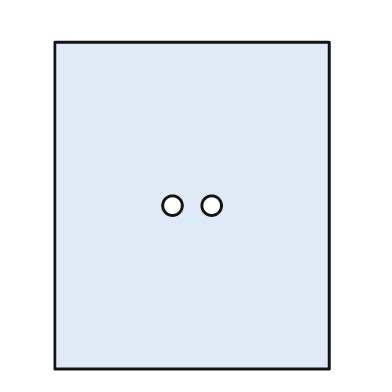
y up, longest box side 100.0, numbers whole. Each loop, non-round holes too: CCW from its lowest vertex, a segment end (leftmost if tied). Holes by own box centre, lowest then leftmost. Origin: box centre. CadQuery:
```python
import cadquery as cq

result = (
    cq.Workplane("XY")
    .moveTo(-42.0, -50.0)
    .lineTo(42.0, -50.0)
    .lineTo(42.0, 50.0)
    .lineTo(-42.0, 50.0)
    .close()
    .moveTo(-6.0, 0.0)
    .circle(3.0)
    .moveTo(6.0, 0.0)
    .circle(3.0)
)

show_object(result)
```